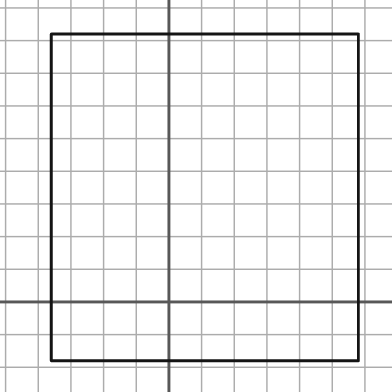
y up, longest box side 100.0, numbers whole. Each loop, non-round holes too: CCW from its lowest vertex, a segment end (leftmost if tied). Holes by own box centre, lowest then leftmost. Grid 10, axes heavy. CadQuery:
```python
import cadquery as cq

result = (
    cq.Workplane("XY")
    .moveTo(-36.0, -18.0)
    .lineTo(58.0, -18.0)
    .lineTo(58.0, 82.0)
    .lineTo(-36.0, 82.0)
    .close()
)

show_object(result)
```